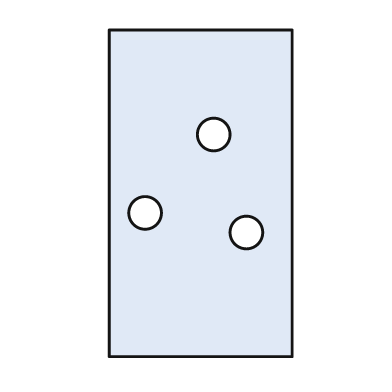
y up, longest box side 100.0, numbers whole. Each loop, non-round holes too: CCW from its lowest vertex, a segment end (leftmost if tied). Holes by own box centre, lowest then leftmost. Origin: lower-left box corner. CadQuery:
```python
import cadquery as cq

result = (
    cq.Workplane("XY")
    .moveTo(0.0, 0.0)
    .lineTo(56.0, 0.0)
    .lineTo(56.0, 100.0)
    .lineTo(0.0, 100.0)
    .close()
    .moveTo(42.0, 38.0)
    .circle(5.0)
    .moveTo(11.0, 44.0)
    .circle(5.0)
    .moveTo(32.0, 68.0)
    .circle(5.0)
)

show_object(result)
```